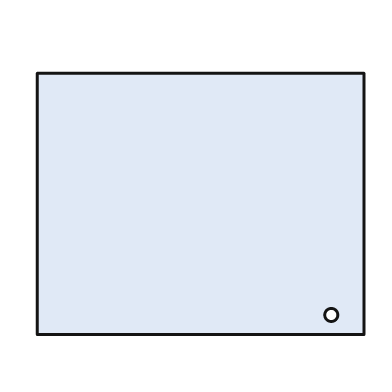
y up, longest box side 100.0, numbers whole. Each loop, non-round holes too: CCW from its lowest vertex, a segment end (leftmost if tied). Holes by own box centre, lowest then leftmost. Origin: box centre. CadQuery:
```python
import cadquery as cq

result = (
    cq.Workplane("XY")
    .moveTo(-50.0, -40.0)
    .lineTo(50.0, -40.0)
    .lineTo(50.0, 40.0)
    .lineTo(-50.0, 40.0)
    .close()
    .moveTo(40.0, -34.0)
    .circle(2.0)
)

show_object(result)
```